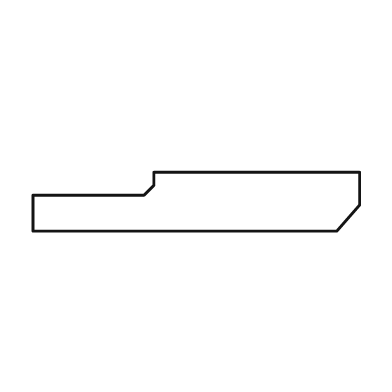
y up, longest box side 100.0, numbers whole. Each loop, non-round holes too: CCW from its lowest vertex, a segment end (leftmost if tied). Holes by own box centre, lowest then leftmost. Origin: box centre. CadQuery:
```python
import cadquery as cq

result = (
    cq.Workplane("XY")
    .moveTo(-50.0, -9.0)
    .lineTo(43.0, -9.0)
    .lineTo(50.0, -1.0)
    .lineTo(50.0, 9.0)
    .lineTo(-13.0, 9.0)
    .lineTo(-13.0, 5.0)
    .lineTo(-16.0, 2.0)
    .lineTo(-50.0, 2.0)
    .close()
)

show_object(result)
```